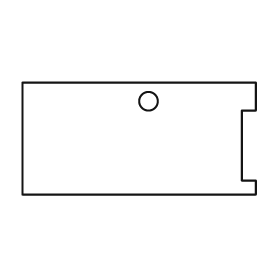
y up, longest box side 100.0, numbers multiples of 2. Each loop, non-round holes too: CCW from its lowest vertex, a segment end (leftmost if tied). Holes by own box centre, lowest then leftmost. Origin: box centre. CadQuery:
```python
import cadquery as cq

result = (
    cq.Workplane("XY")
    .moveTo(-50.0, -24.0)
    .lineTo(50.0, -24.0)
    .lineTo(50.0, -18.0)
    .lineTo(44.0, -18.0)
    .lineTo(44.0, 12.0)
    .lineTo(50.0, 12.0)
    .lineTo(50.0, 24.0)
    .lineTo(-50.0, 24.0)
    .close()
    .moveTo(4.0, 16.0)
    .circle(4.0)
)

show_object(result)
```